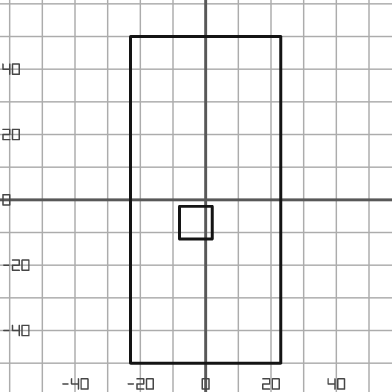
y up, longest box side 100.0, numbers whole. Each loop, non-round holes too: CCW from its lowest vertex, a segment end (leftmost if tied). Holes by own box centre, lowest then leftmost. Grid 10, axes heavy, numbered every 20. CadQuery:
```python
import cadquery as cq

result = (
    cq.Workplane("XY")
    .moveTo(-23.0, -50.0)
    .lineTo(23.0, -50.0)
    .lineTo(23.0, 50.0)
    .lineTo(-23.0, 50.0)
    .close()
    .moveTo(-8.0, -12.0)
    .lineTo(2.0, -12.0)
    .lineTo(2.0, -2.0)
    .lineTo(-8.0, -2.0)
    .close()
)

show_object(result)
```